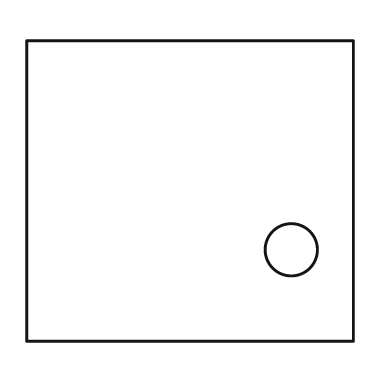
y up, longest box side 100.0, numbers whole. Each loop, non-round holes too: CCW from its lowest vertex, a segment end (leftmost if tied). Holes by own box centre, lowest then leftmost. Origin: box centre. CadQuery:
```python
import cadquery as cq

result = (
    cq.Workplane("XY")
    .moveTo(-50.0, -46.0)
    .lineTo(50.0, -46.0)
    .lineTo(50.0, 46.0)
    .lineTo(-50.0, 46.0)
    .close()
    .moveTo(31.0, -18.0)
    .circle(8.0)
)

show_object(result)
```